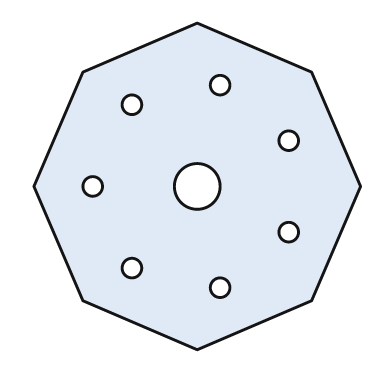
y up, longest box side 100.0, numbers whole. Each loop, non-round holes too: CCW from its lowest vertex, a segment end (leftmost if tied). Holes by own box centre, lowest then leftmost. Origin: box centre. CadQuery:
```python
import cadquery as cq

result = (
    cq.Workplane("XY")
    .moveTo(0.0, -50.0)
    .lineTo(35.0, -35.0)
    .lineTo(50.0, 0.0)
    .lineTo(35.0, 35.0)
    .lineTo(0.0, 50.0)
    .lineTo(-35.0, 35.0)
    .lineTo(-50.0, 0.0)
    .lineTo(-35.0, -35.0)
    .close()
    .moveTo(7.0, -31.0)
    .circle(3.0)
    .moveTo(-20.0, -25.0)
    .circle(3.0)
    .moveTo(28.0, -14.0)
    .circle(3.0)
    .moveTo(-32.0, 0.0)
    .circle(3.0)
    .moveTo(0.0, 0.0)
    .circle(7.0)
    .moveTo(28.0, 14.0)
    .circle(3.0)
    .moveTo(-20.0, 25.0)
    .circle(3.0)
    .moveTo(7.0, 31.0)
    .circle(3.0)
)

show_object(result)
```